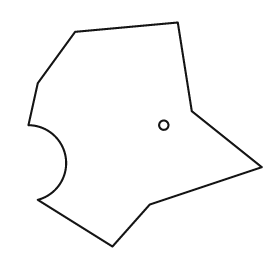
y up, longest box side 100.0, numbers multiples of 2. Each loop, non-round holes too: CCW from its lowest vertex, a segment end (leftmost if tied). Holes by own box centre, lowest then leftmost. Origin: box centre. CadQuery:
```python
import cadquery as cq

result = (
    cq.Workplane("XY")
    .moveTo(-14.0, -48.0)
    .lineTo(2.0, -30.0)
    .lineTo(50.0, -14.0)
    .lineTo(20.0, 10.0)
    .lineTo(14.0, 48.0)
    .lineTo(-30.0, 44.0)
    .lineTo(-46.0, 22.0)
    .lineTo(-50.0, 4.0)
    .threePointArc((-34.0, -10.0), (-46.0, -28.0))
    .close()
    .moveTo(8.0, 4.0)
    .circle(2.0)
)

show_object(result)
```